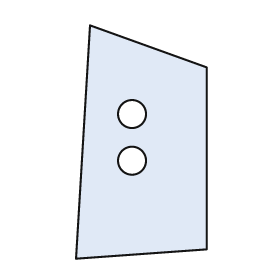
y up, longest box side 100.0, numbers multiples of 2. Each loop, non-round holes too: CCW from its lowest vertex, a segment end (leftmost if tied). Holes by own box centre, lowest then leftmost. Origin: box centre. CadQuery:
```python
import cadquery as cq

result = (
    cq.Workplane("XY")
    .moveTo(-28.0, -50.0)
    .lineTo(28.0, -46.0)
    .lineTo(28.0, 32.0)
    .lineTo(-22.0, 50.0)
    .close()
    .moveTo(-4.0, -8.0)
    .circle(6.0)
    .moveTo(-4.0, 12.0)
    .circle(6.0)
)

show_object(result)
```